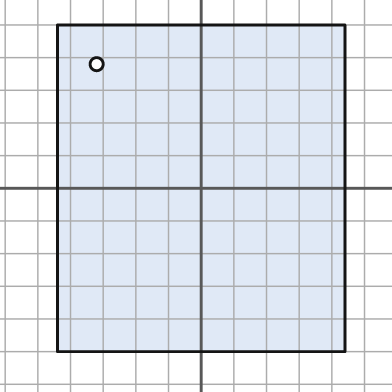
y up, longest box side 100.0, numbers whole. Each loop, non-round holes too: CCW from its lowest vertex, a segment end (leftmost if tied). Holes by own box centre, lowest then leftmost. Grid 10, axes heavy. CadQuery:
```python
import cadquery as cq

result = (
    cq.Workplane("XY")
    .moveTo(-44.0, -50.0)
    .lineTo(44.0, -50.0)
    .lineTo(44.0, 50.0)
    .lineTo(-44.0, 50.0)
    .close()
    .moveTo(-32.0, 38.0)
    .circle(2.0)
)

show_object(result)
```